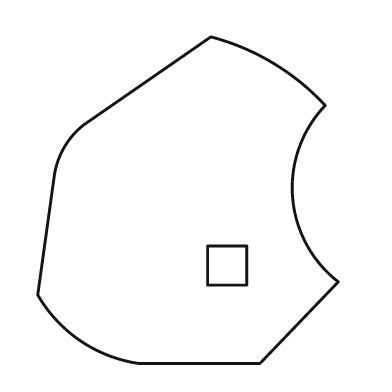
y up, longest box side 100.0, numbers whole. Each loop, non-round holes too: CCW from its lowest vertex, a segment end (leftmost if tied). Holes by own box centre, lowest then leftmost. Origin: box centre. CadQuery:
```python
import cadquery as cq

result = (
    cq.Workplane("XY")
    .moveTo(-15.0, -50.0)
    .lineTo(22.0, -50.0)
    .lineTo(46.0, -25.0)
    .threePointArc((32.0, 1.0), (42.0, 29.0))
    .threePointArc((26.0, 42.0), (7.0, 50.0))
    .lineTo(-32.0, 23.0)
    .threePointArc((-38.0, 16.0), (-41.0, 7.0))
    .lineTo(-46.0, -29.0)
    .threePointArc((-33.0, -43.0), (-15.0, -50.0))
    .close()
    .moveTo(6.0, -26.0)
    .lineTo(18.0, -26.0)
    .lineTo(18.0, -14.0)
    .lineTo(6.0, -14.0)
    .close()
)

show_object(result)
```